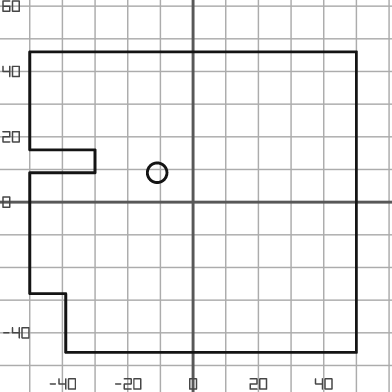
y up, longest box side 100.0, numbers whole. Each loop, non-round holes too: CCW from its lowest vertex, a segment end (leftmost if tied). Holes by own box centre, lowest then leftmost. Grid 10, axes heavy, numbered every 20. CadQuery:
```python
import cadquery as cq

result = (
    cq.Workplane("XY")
    .moveTo(-39.0, -46.0)
    .lineTo(50.0, -46.0)
    .lineTo(50.0, 46.0)
    .lineTo(-50.0, 46.0)
    .lineTo(-50.0, 16.0)
    .lineTo(-30.0, 16.0)
    .lineTo(-30.0, 9.0)
    .lineTo(-50.0, 9.0)
    .lineTo(-50.0, -28.0)
    .lineTo(-39.0, -28.0)
    .close()
    .moveTo(-11.0, 9.0)
    .circle(3.0)
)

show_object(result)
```